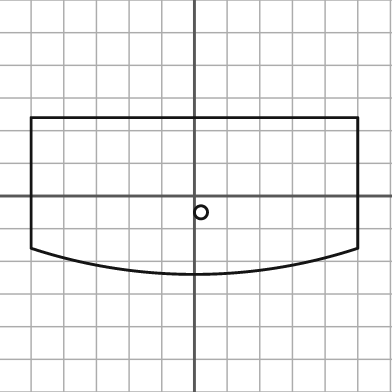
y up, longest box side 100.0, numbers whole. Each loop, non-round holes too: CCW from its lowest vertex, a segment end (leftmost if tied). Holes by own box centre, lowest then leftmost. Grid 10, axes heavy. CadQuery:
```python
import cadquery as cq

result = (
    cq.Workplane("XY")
    .moveTo(-50.0, -16.0)
    .threePointArc((0.0, -24.0), (50.0, -16.0))
    .lineTo(50.0, 24.0)
    .lineTo(-50.0, 24.0)
    .close()
    .moveTo(2.0, -5.0)
    .circle(2.0)
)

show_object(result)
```